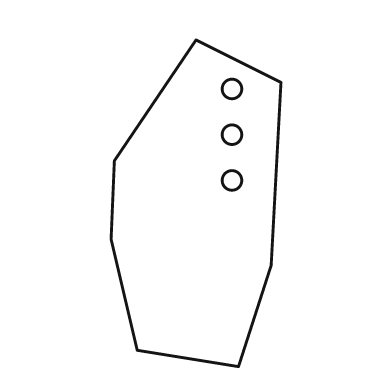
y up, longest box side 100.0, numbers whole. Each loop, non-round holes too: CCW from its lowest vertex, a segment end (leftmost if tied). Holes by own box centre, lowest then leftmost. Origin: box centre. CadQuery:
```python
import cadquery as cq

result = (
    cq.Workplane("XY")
    .moveTo(13.0, -50.0)
    .lineTo(23.0, -19.0)
    .lineTo(26.0, 37.0)
    .lineTo(0.0, 50.0)
    .lineTo(-25.0, 13.0)
    .lineTo(-26.0, -11.0)
    .lineTo(-18.0, -45.0)
    .close()
    .moveTo(11.0, 7.0)
    .circle(3.0)
    .moveTo(11.0, 21.0)
    .circle(3.0)
    .moveTo(11.0, 35.0)
    .circle(3.0)
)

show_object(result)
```